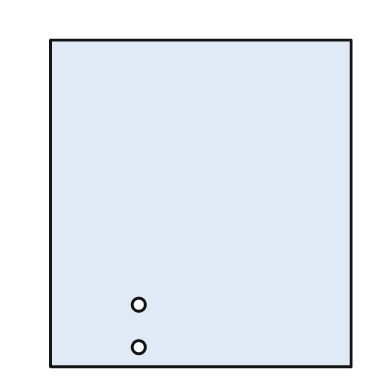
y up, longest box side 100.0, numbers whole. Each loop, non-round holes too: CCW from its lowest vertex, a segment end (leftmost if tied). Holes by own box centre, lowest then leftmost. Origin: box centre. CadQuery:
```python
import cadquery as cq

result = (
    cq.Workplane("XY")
    .moveTo(-46.0, -50.0)
    .lineTo(46.0, -50.0)
    .lineTo(46.0, 50.0)
    .lineTo(-46.0, 50.0)
    .close()
    .moveTo(-19.0, -44.0)
    .circle(2.0)
    .moveTo(-19.0, -31.0)
    .circle(2.0)
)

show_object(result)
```